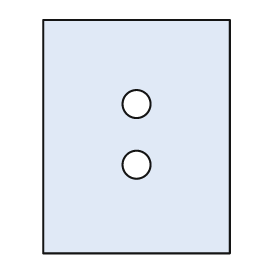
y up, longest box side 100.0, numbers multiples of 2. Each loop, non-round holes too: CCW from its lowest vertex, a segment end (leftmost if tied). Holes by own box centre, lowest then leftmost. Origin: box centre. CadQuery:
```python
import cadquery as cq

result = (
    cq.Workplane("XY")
    .moveTo(-40.0, -50.0)
    .lineTo(40.0, -50.0)
    .lineTo(40.0, 50.0)
    .lineTo(-40.0, 50.0)
    .close()
    .moveTo(0.0, -12.0)
    .circle(6.0)
    .moveTo(0.0, 14.0)
    .circle(6.0)
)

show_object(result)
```